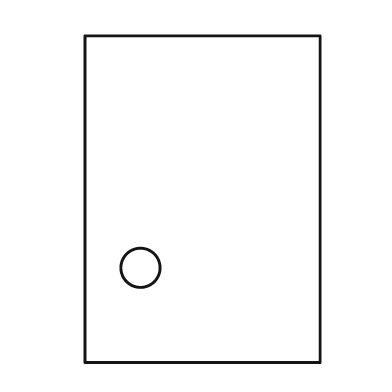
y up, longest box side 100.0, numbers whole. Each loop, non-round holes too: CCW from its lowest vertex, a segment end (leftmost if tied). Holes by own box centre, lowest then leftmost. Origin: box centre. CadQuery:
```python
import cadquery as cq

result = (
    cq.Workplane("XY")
    .moveTo(-36.0, -50.0)
    .lineTo(36.0, -50.0)
    .lineTo(36.0, 50.0)
    .lineTo(-36.0, 50.0)
    .close()
    .moveTo(-19.0, -21.0)
    .circle(6.0)
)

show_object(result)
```